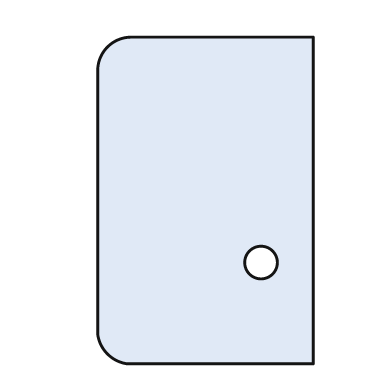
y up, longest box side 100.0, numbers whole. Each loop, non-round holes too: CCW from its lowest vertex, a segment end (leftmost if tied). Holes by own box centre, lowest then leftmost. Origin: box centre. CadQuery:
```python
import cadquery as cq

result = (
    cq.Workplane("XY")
    .moveTo(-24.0, -50.0)
    .lineTo(33.0, -50.0)
    .lineTo(33.0, 50.0)
    .lineTo(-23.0, 50.0)
    .threePointArc((-30.0, 47.0), (-33.0, 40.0))
    .lineTo(-33.0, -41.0)
    .threePointArc((-30.0, -47.0), (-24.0, -50.0))
    .close()
    .moveTo(17.0, -19.0)
    .circle(5.0)
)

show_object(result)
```